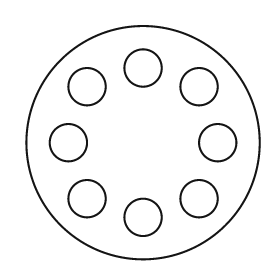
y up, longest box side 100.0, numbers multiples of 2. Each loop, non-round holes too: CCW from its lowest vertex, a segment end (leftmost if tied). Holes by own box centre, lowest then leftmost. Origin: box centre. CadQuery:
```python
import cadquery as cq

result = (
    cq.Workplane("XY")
    .moveTo(0.0, 0.0)
    .circle(50.0)
    .moveTo(0.0, -32.0)
    .circle(8.0)
    .moveTo(-24.0, -24.0)
    .circle(8.0)
    .moveTo(24.0, -24.0)
    .circle(8.0)
    .moveTo(-32.0, 0.0)
    .circle(8.0)
    .moveTo(32.0, 0.0)
    .circle(8.0)
    .moveTo(-24.0, 24.0)
    .circle(8.0)
    .moveTo(24.0, 24.0)
    .circle(8.0)
    .moveTo(0.0, 32.0)
    .circle(8.0)
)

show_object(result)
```